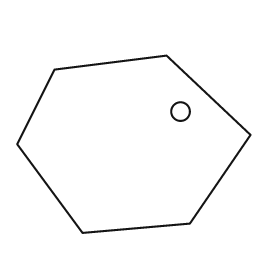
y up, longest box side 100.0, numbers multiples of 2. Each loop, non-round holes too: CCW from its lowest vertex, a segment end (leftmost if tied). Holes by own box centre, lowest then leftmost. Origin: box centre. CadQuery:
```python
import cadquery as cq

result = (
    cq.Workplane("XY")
    .moveTo(-22.0, -38.0)
    .lineTo(24.0, -34.0)
    .lineTo(50.0, 4.0)
    .lineTo(14.0, 38.0)
    .lineTo(-34.0, 32.0)
    .lineTo(-50.0, 0.0)
    .close()
    .moveTo(20.0, 14.0)
    .circle(4.0)
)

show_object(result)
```